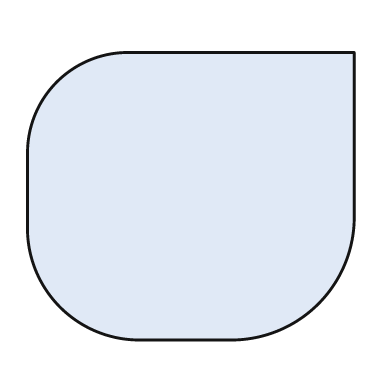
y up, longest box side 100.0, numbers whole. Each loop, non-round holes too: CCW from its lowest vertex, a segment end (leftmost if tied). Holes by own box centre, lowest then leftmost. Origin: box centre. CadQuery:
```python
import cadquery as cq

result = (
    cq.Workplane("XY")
    .moveTo(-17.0, -44.0)
    .lineTo(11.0, -44.0)
    .threePointArc((39.0, -33.0), (50.0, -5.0))
    .lineTo(50.0, 44.0)
    .lineTo(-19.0, 44.0)
    .threePointArc((-41.0, 35.0), (-50.0, 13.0))
    .lineTo(-50.0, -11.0)
    .threePointArc((-40.0, -34.0), (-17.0, -44.0))
    .close()
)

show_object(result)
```